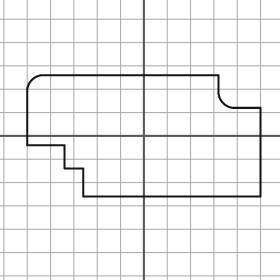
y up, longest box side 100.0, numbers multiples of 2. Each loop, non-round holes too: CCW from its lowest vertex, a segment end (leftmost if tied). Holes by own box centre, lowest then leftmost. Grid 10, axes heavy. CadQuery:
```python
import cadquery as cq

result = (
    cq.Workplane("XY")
    .moveTo(-26.0, -26.0)
    .lineTo(50.0, -26.0)
    .lineTo(50.0, 12.0)
    .lineTo(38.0, 12.0)
    .threePointArc((34.0, 14.0), (32.0, 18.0))
    .lineTo(32.0, 26.0)
    .lineTo(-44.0, 26.0)
    .threePointArc((-48.0, 24.0), (-50.0, 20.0))
    .lineTo(-50.0, -4.0)
    .lineTo(-34.0, -4.0)
    .lineTo(-34.0, -14.0)
    .lineTo(-26.0, -14.0)
    .close()
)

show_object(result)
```